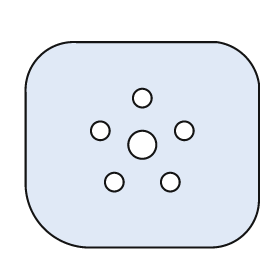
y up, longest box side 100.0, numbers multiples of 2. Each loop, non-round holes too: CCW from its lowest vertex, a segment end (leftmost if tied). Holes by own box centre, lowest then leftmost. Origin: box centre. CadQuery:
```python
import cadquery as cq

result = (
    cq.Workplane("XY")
    .moveTo(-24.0, -44.0)
    .lineTo(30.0, -44.0)
    .threePointArc((44.0, -38.0), (50.0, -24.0))
    .lineTo(50.0, 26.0)
    .threePointArc((44.0, 38.0), (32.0, 44.0))
    .lineTo(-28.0, 44.0)
    .threePointArc((-44.0, 38.0), (-50.0, 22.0))
    .lineTo(-50.0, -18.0)
    .threePointArc((-42.0, -36.0), (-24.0, -44.0))
    .close()
    .moveTo(-12.0, -16.0)
    .circle(4.0)
    .moveTo(12.0, -16.0)
    .circle(4.0)
    .moveTo(0.0, 0.0)
    .circle(6.0)
    .moveTo(-18.0, 6.0)
    .circle(4.0)
    .moveTo(18.0, 6.0)
    .circle(4.0)
    .moveTo(0.0, 20.0)
    .circle(4.0)
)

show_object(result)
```